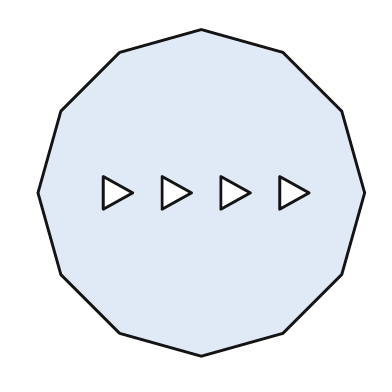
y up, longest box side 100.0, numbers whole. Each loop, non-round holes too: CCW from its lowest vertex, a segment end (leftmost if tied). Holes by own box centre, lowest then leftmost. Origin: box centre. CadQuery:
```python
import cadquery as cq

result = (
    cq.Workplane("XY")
    .moveTo(0.0, -50.0)
    .lineTo(25.0, -43.0)
    .lineTo(43.0, -25.0)
    .lineTo(50.0, 0.0)
    .lineTo(43.0, 25.0)
    .lineTo(25.0, 43.0)
    .lineTo(0.0, 50.0)
    .lineTo(-25.0, 43.0)
    .lineTo(-43.0, 25.0)
    .lineTo(-50.0, 0.0)
    .lineTo(-43.0, -25.0)
    .lineTo(-25.0, -43.0)
    .close()
    .moveTo(-30.0, -5.0)
    .lineTo(-21.0, 0.0)
    .lineTo(-30.0, 5.0)
    .close()
    .moveTo(-12.0, -5.0)
    .lineTo(-3.0, 0.0)
    .lineTo(-12.0, 5.0)
    .close()
    .moveTo(6.0, -5.0)
    .lineTo(15.0, 0.0)
    .lineTo(6.0, 5.0)
    .close()
    .moveTo(24.0, -5.0)
    .lineTo(33.0, 0.0)
    .lineTo(24.0, 5.0)
    .close()
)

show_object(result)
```